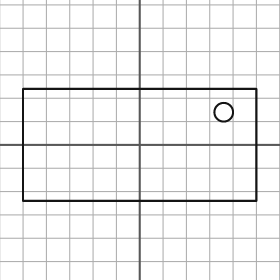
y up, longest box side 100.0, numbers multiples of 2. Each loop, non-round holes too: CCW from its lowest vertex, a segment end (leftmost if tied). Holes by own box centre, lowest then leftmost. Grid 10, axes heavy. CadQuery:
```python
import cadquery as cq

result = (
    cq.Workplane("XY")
    .moveTo(-50.0, -24.0)
    .lineTo(50.0, -24.0)
    .lineTo(50.0, 24.0)
    .lineTo(-50.0, 24.0)
    .close()
    .moveTo(36.0, 14.0)
    .circle(4.0)
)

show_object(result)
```